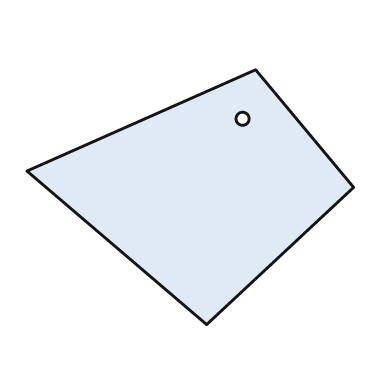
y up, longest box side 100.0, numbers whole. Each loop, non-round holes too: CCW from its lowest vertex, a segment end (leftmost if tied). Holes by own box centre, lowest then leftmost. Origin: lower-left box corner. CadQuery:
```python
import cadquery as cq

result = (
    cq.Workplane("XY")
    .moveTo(55.0, 0.0)
    .lineTo(100.0, 42.0)
    .lineTo(70.0, 78.0)
    .lineTo(0.0, 47.0)
    .close()
    .moveTo(66.0, 63.0)
    .circle(2.0)
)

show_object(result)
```